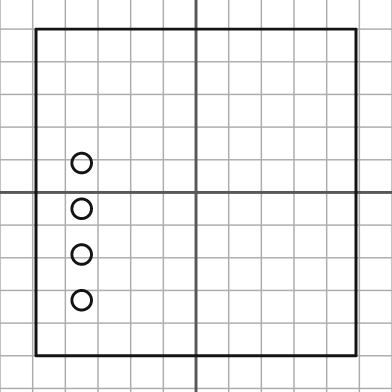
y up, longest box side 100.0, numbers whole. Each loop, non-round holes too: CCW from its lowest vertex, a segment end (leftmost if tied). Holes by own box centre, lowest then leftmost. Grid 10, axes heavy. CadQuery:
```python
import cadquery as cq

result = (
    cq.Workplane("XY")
    .moveTo(-49.0, -50.0)
    .lineTo(49.0, -50.0)
    .lineTo(49.0, 50.0)
    .lineTo(-49.0, 50.0)
    .close()
    .moveTo(-35.0, -33.0)
    .circle(3.0)
    .moveTo(-35.0, -19.0)
    .circle(3.0)
    .moveTo(-35.0, -5.0)
    .circle(3.0)
    .moveTo(-35.0, 9.0)
    .circle(3.0)
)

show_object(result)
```